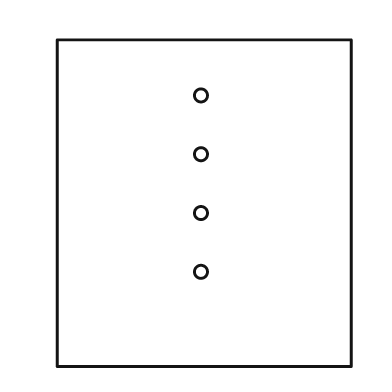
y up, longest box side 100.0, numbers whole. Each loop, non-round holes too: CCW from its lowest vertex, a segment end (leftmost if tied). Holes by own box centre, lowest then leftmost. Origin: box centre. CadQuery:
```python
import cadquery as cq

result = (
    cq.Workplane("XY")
    .moveTo(-45.0, -50.0)
    .lineTo(45.0, -50.0)
    .lineTo(45.0, 50.0)
    .lineTo(-45.0, 50.0)
    .close()
    .moveTo(-1.0, -21.0)
    .circle(2.0)
    .moveTo(-1.0, -3.0)
    .circle(2.0)
    .moveTo(-1.0, 15.0)
    .circle(2.0)
    .moveTo(-1.0, 33.0)
    .circle(2.0)
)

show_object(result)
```